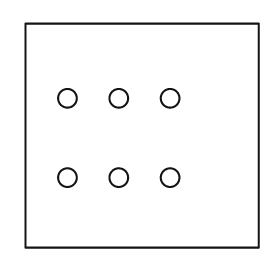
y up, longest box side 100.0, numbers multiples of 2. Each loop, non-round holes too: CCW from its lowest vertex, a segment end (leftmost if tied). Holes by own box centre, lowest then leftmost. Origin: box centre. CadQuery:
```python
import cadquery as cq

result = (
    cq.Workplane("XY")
    .moveTo(-50.0, -48.0)
    .lineTo(50.0, -48.0)
    .lineTo(50.0, 48.0)
    .lineTo(-50.0, 48.0)
    .close()
    .moveTo(-32.0, -18.0)
    .circle(4.0)
    .moveTo(-10.0, -18.0)
    .circle(4.0)
    .moveTo(12.0, -18.0)
    .circle(4.0)
    .moveTo(-32.0, 16.0)
    .circle(4.0)
    .moveTo(-10.0, 16.0)
    .circle(4.0)
    .moveTo(12.0, 16.0)
    .circle(4.0)
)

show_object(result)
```